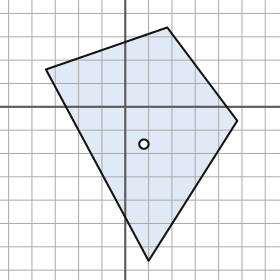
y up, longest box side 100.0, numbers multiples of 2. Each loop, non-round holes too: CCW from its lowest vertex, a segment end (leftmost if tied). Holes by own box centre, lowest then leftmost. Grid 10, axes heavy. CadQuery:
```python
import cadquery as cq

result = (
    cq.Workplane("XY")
    .moveTo(10.0, -66.0)
    .lineTo(48.0, -6.0)
    .lineTo(18.0, 34.0)
    .lineTo(-34.0, 16.0)
    .close()
    .moveTo(8.0, -16.0)
    .circle(2.0)
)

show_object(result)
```